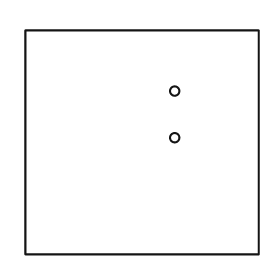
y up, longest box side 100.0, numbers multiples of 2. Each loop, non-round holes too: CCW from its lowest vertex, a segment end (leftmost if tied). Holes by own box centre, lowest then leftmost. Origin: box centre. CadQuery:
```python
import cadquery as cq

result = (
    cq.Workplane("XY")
    .moveTo(-50.0, -48.0)
    .lineTo(50.0, -48.0)
    .lineTo(50.0, 48.0)
    .lineTo(-50.0, 48.0)
    .close()
    .moveTo(14.0, 2.0)
    .circle(2.0)
    .moveTo(14.0, 22.0)
    .circle(2.0)
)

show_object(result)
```